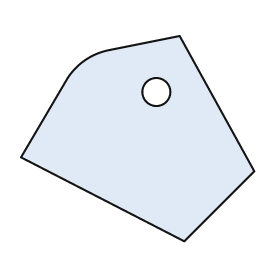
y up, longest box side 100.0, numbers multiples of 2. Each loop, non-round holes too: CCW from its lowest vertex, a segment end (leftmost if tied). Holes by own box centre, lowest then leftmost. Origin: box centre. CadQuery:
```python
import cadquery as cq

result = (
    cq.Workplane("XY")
    .moveTo(20.0, -44.0)
    .lineTo(50.0, -14.0)
    .lineTo(18.0, 44.0)
    .lineTo(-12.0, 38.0)
    .threePointArc((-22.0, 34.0), (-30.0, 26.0))
    .lineTo(-50.0, -8.0)
    .close()
    .moveTo(8.0, 20.0)
    .circle(6.0)
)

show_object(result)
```